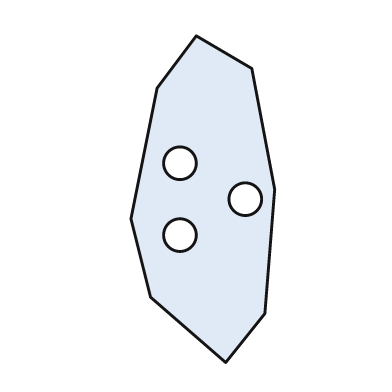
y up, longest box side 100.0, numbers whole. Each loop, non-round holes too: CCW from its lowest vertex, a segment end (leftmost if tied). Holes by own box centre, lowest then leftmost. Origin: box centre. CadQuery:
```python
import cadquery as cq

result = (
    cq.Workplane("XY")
    .moveTo(7.0, -50.0)
    .lineTo(19.0, -35.0)
    .lineTo(22.0, 3.0)
    .lineTo(15.0, 40.0)
    .lineTo(-2.0, 50.0)
    .lineTo(-14.0, 34.0)
    .lineTo(-22.0, -6.0)
    .lineTo(-16.0, -30.0)
    .close()
    .moveTo(-7.0, -11.0)
    .circle(5.0)
    .moveTo(13.0, 0.0)
    .circle(5.0)
    .moveTo(-7.0, 11.0)
    .circle(5.0)
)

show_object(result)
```